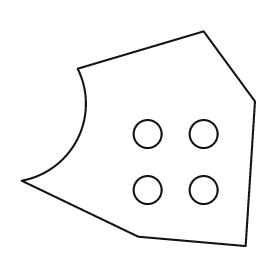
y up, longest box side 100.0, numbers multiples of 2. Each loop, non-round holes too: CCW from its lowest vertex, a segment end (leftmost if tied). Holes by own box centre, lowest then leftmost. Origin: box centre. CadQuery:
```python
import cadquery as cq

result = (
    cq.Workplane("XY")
    .moveTo(46.0, -46.0)
    .lineTo(50.0, 16.0)
    .lineTo(28.0, 46.0)
    .lineTo(-26.0, 30.0)
    .threePointArc((-26.0, 0.0), (-50.0, -18.0))
    .lineTo(0.0, -42.0)
    .close()
    .moveTo(4.0, -22.0)
    .circle(6.0)
    .moveTo(28.0, -22.0)
    .circle(6.0)
    .moveTo(4.0, 2.0)
    .circle(6.0)
    .moveTo(28.0, 2.0)
    .circle(6.0)
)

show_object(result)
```